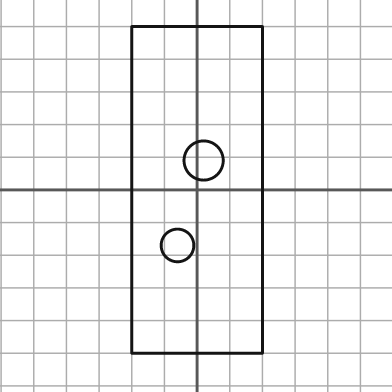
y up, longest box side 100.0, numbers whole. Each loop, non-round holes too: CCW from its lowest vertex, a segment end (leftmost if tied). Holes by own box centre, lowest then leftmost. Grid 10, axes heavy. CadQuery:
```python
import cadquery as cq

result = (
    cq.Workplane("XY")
    .moveTo(-20.0, -50.0)
    .lineTo(20.0, -50.0)
    .lineTo(20.0, 50.0)
    .lineTo(-20.0, 50.0)
    .close()
    .moveTo(-6.0, -17.0)
    .circle(5.0)
    .moveTo(2.0, 9.0)
    .circle(6.0)
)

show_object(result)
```